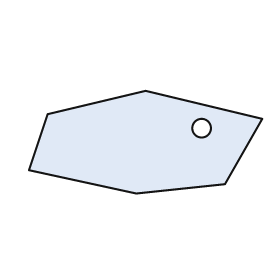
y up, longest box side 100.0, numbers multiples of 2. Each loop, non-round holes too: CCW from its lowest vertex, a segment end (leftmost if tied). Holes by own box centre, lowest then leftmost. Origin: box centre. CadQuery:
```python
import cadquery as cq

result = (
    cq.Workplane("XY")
    .moveTo(-4.0, -22.0)
    .lineTo(34.0, -18.0)
    .lineTo(50.0, 10.0)
    .lineTo(0.0, 22.0)
    .lineTo(-42.0, 12.0)
    .lineTo(-50.0, -12.0)
    .close()
    .moveTo(24.0, 6.0)
    .circle(4.0)
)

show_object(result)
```